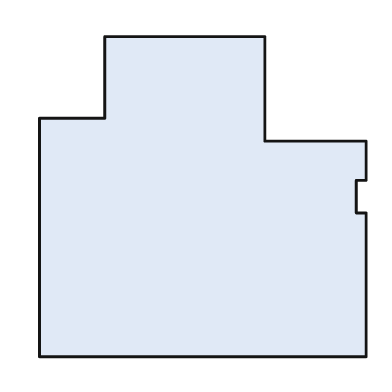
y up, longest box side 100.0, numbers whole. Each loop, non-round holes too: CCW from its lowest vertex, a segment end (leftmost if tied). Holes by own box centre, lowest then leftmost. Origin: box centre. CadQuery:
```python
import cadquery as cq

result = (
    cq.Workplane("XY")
    .moveTo(-50.0, -49.0)
    .lineTo(50.0, -49.0)
    .lineTo(50.0, -5.0)
    .lineTo(47.0, -5.0)
    .lineTo(47.0, 5.0)
    .lineTo(50.0, 5.0)
    .lineTo(50.0, 17.0)
    .lineTo(19.0, 17.0)
    .lineTo(19.0, 49.0)
    .lineTo(-30.0, 49.0)
    .lineTo(-30.0, 24.0)
    .lineTo(-50.0, 24.0)
    .close()
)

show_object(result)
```